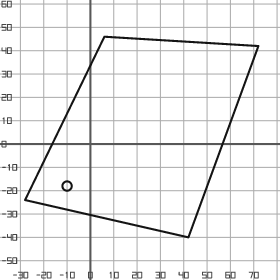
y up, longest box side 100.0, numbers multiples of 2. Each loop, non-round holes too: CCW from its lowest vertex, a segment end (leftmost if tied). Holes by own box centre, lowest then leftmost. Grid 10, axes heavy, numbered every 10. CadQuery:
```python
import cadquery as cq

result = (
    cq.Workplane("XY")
    .moveTo(42.0, -40.0)
    .lineTo(72.0, 42.0)
    .lineTo(6.0, 46.0)
    .lineTo(-28.0, -24.0)
    .close()
    .moveTo(-10.0, -18.0)
    .circle(2.0)
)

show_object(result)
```